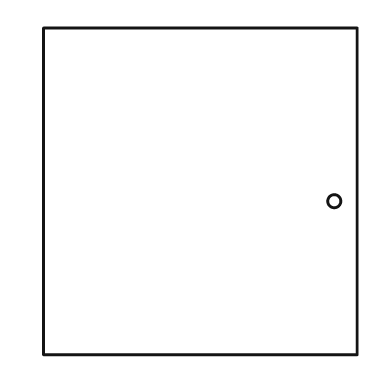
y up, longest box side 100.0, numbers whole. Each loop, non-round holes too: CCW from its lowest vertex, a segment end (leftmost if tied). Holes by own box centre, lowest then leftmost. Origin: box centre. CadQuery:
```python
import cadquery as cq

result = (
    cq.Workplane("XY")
    .moveTo(-48.0, -50.0)
    .lineTo(48.0, -50.0)
    .lineTo(48.0, 50.0)
    .lineTo(-48.0, 50.0)
    .close()
    .moveTo(41.0, -3.0)
    .circle(2.0)
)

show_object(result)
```